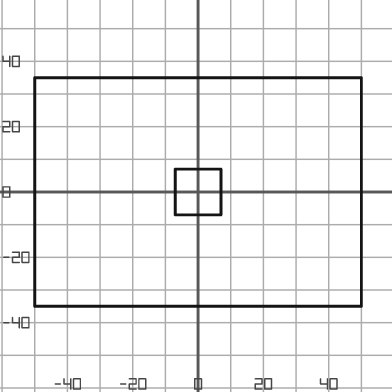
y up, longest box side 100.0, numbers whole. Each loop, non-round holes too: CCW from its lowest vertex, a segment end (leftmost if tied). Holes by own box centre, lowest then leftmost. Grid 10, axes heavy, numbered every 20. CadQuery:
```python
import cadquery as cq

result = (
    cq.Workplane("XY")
    .moveTo(-50.0, -35.0)
    .lineTo(50.0, -35.0)
    .lineTo(50.0, 35.0)
    .lineTo(-50.0, 35.0)
    .close()
    .moveTo(-7.0, -7.0)
    .lineTo(7.0, -7.0)
    .lineTo(7.0, 7.0)
    .lineTo(-7.0, 7.0)
    .close()
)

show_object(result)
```